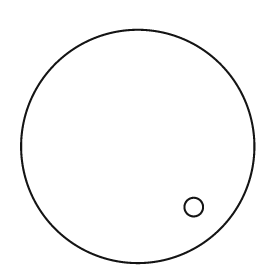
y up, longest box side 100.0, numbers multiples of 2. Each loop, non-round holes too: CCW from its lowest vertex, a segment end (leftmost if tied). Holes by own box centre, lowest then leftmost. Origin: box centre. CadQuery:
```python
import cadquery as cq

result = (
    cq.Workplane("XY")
    .moveTo(0.0, 0.0)
    .circle(50.0)
    .moveTo(24.0, -26.0)
    .circle(4.0)
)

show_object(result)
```